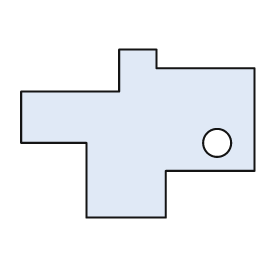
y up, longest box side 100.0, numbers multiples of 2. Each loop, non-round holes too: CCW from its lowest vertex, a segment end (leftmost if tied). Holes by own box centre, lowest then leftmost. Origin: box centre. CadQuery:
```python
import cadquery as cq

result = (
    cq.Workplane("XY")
    .moveTo(-22.0, -36.0)
    .lineTo(12.0, -36.0)
    .lineTo(12.0, -16.0)
    .lineTo(50.0, -16.0)
    .lineTo(50.0, 28.0)
    .lineTo(8.0, 28.0)
    .lineTo(8.0, 36.0)
    .lineTo(-8.0, 36.0)
    .lineTo(-8.0, 18.0)
    .lineTo(-50.0, 18.0)
    .lineTo(-50.0, -4.0)
    .lineTo(-22.0, -4.0)
    .close()
    .moveTo(34.0, -4.0)
    .circle(6.0)
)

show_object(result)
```